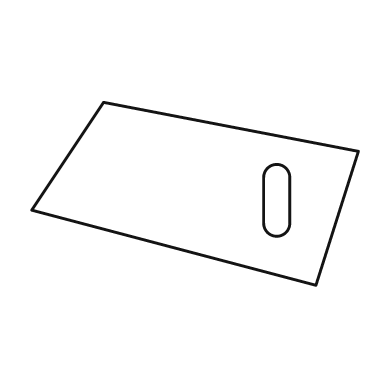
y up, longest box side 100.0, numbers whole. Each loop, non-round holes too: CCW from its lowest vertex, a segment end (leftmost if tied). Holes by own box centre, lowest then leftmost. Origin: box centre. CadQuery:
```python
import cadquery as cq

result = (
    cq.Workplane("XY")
    .moveTo(37.0, -28.0)
    .lineTo(50.0, 13.0)
    .lineTo(-28.0, 28.0)
    .lineTo(-50.0, -5.0)
    .close()
    .moveTo(21.0, -9.0)
    .threePointArc((25.0, -13.0), (29.0, -9.0))
    .lineTo(29.0, 5.0)
    .threePointArc((25.0, 9.0), (21.0, 5.0))
    .close()
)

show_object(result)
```